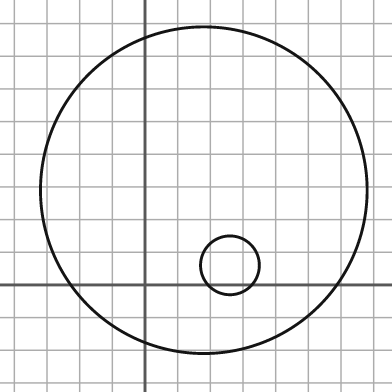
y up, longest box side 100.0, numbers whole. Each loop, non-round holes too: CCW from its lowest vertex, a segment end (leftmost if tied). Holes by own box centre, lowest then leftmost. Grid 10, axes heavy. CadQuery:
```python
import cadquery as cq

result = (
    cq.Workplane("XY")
    .moveTo(18.0, 29.0)
    .circle(50.0)
    .moveTo(26.0, 6.0)
    .circle(9.0)
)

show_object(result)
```